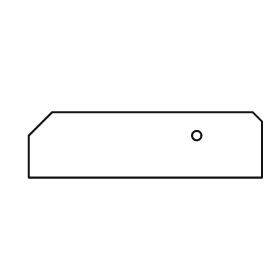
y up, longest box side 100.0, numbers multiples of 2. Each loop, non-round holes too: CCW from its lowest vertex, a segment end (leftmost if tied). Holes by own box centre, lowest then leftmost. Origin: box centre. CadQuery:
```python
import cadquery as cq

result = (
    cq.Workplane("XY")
    .moveTo(-50.0, -14.0)
    .lineTo(50.0, -14.0)
    .lineTo(50.0, 10.0)
    .lineTo(46.0, 14.0)
    .lineTo(-40.0, 14.0)
    .lineTo(-50.0, 4.0)
    .close()
    .moveTo(22.0, 4.0)
    .circle(2.0)
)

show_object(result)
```